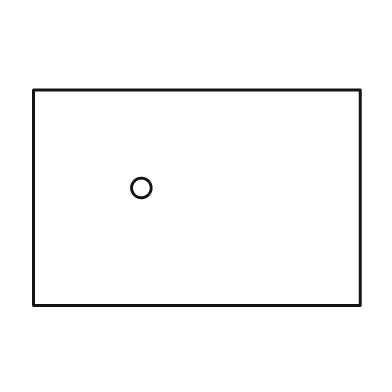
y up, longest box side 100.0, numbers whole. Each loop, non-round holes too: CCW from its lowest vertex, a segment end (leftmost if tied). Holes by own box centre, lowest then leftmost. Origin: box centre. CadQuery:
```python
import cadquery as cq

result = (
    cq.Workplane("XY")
    .moveTo(-50.0, -33.0)
    .lineTo(50.0, -33.0)
    .lineTo(50.0, 33.0)
    .lineTo(-50.0, 33.0)
    .close()
    .moveTo(-17.0, 3.0)
    .circle(3.0)
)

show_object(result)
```